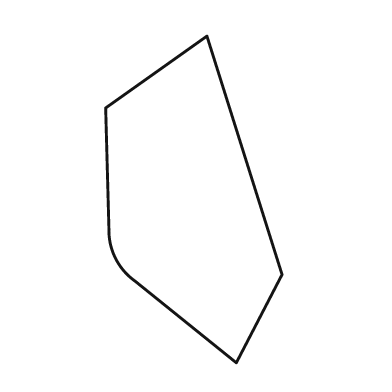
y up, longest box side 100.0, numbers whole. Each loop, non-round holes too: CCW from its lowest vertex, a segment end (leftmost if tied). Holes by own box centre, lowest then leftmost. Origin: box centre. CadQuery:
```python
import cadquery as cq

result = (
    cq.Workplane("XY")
    .moveTo(13.0, -50.0)
    .lineTo(27.0, -23.0)
    .lineTo(4.0, 50.0)
    .lineTo(-27.0, 28.0)
    .lineTo(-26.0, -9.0)
    .threePointArc((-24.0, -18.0), (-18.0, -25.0))
    .close()
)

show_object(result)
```